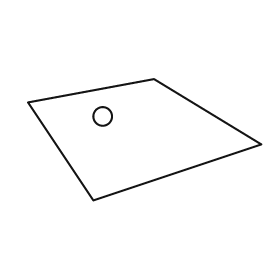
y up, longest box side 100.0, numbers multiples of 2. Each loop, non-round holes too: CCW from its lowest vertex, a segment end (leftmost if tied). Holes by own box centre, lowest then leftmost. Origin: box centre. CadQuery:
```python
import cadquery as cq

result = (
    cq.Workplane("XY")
    .moveTo(-22.0, -26.0)
    .lineTo(50.0, -2.0)
    .lineTo(4.0, 26.0)
    .lineTo(-50.0, 16.0)
    .close()
    .moveTo(-18.0, 10.0)
    .circle(4.0)
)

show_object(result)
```